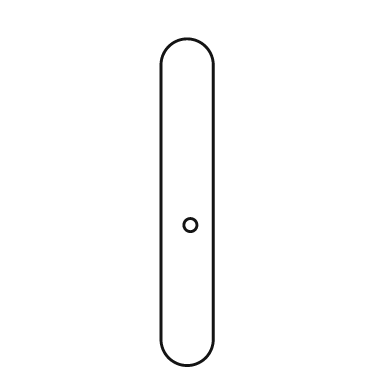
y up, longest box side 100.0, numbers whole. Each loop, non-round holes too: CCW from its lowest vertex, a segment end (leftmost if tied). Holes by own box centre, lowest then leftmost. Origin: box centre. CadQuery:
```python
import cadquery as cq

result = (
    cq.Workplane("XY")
    .moveTo(-8.0, -42.0)
    .threePointArc((0.0, -50.0), (8.0, -42.0))
    .lineTo(8.0, 42.0)
    .threePointArc((0.0, 50.0), (-8.0, 42.0))
    .close()
    .moveTo(1.0, -7.0)
    .circle(2.0)
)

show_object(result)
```